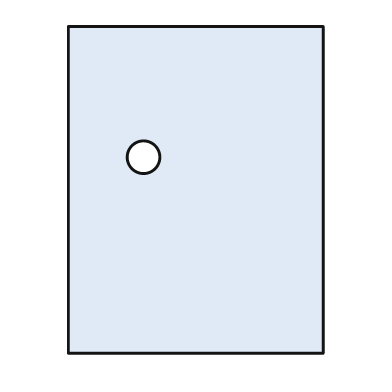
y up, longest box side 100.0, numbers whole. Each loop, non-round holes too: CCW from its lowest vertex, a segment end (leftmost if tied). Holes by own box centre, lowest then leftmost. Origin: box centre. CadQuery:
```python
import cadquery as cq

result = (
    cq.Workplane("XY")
    .moveTo(-39.0, -50.0)
    .lineTo(39.0, -50.0)
    .lineTo(39.0, 50.0)
    .lineTo(-39.0, 50.0)
    .close()
    .moveTo(-16.0, 10.0)
    .circle(5.0)
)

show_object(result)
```